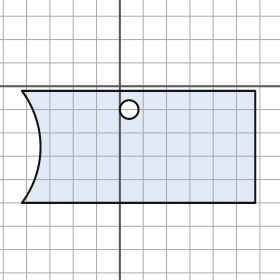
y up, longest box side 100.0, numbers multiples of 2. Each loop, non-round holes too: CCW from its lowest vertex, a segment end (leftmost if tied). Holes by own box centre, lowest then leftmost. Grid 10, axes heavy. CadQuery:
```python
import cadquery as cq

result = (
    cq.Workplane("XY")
    .moveTo(-42.0, -50.0)
    .lineTo(58.0, -50.0)
    .lineTo(58.0, -2.0)
    .lineTo(-42.0, -2.0)
    .threePointArc((-34.0, -26.0), (-42.0, -50.0))
    .close()
    .moveTo(4.0, -10.0)
    .circle(4.0)
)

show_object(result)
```